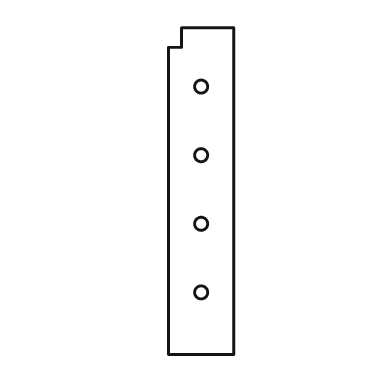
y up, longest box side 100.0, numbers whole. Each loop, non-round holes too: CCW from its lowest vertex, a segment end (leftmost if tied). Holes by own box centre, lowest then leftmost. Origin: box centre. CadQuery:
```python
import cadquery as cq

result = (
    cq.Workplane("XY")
    .moveTo(-10.0, -50.0)
    .lineTo(10.0, -50.0)
    .lineTo(10.0, 50.0)
    .lineTo(-6.0, 50.0)
    .lineTo(-6.0, 44.0)
    .lineTo(-10.0, 44.0)
    .close()
    .moveTo(0.0, -31.0)
    .circle(2.0)
    .moveTo(0.0, -10.0)
    .circle(2.0)
    .moveTo(0.0, 11.0)
    .circle(2.0)
    .moveTo(0.0, 32.0)
    .circle(2.0)
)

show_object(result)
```